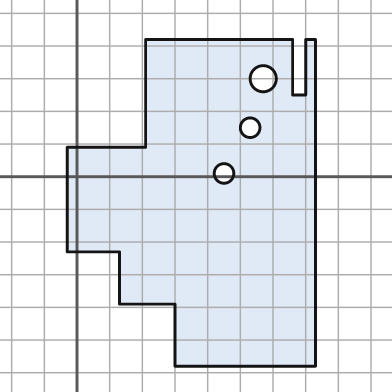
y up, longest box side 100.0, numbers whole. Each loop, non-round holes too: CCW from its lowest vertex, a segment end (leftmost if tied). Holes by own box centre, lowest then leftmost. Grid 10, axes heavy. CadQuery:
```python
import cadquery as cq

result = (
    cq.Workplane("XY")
    .moveTo(30.0, -58.0)
    .lineTo(73.0, -58.0)
    .lineTo(73.0, 42.0)
    .lineTo(70.0, 42.0)
    .lineTo(70.0, 25.0)
    .lineTo(66.0, 25.0)
    .lineTo(66.0, 42.0)
    .lineTo(21.0, 42.0)
    .lineTo(21.0, 9.0)
    .lineTo(-3.0, 9.0)
    .lineTo(-3.0, -23.0)
    .lineTo(13.0, -23.0)
    .lineTo(13.0, -39.0)
    .lineTo(30.0, -39.0)
    .close()
    .moveTo(45.0, 1.0)
    .circle(3.0)
    .moveTo(53.0, 15.0)
    .circle(3.0)
    .moveTo(57.0, 30.0)
    .circle(4.0)
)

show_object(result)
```